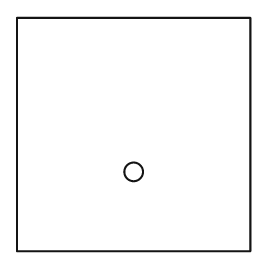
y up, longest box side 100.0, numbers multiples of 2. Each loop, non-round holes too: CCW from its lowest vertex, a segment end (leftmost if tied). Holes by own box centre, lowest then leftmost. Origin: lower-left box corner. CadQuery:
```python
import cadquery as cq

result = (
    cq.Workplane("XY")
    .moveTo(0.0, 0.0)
    .lineTo(100.0, 0.0)
    .lineTo(100.0, 100.0)
    .lineTo(0.0, 100.0)
    .close()
    .moveTo(50.0, 34.0)
    .circle(4.0)
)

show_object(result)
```